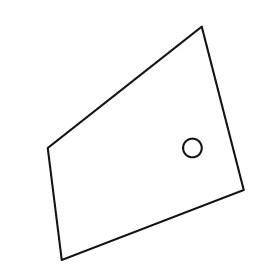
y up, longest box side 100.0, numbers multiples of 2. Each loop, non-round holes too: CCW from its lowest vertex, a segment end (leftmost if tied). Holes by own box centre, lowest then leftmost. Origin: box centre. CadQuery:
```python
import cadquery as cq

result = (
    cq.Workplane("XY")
    .moveTo(-36.0, -50.0)
    .lineTo(42.0, -20.0)
    .lineTo(24.0, 50.0)
    .lineTo(-42.0, -2.0)
    .close()
    .moveTo(20.0, -2.0)
    .circle(4.0)
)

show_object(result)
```